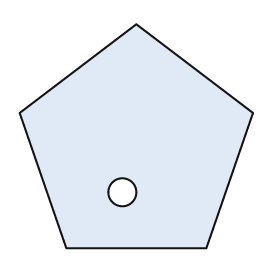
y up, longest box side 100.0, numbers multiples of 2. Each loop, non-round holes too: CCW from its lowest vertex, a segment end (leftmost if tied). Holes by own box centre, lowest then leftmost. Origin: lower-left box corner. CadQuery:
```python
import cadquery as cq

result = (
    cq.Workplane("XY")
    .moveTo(20.0, 0.0)
    .lineTo(80.0, 0.0)
    .lineTo(100.0, 58.0)
    .lineTo(50.0, 96.0)
    .lineTo(0.0, 58.0)
    .close()
    .moveTo(44.0, 24.0)
    .circle(6.0)
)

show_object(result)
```